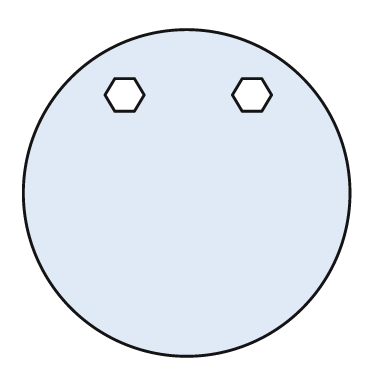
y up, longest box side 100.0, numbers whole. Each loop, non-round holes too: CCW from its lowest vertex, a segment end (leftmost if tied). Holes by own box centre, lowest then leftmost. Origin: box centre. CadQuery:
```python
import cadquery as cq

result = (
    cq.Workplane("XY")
    .moveTo(0.0, 0.0)
    .circle(50.0)
    .moveTo(-22.0, 25.0)
    .lineTo(-16.0, 25.0)
    .lineTo(-13.0, 30.0)
    .lineTo(-16.0, 35.0)
    .lineTo(-22.0, 35.0)
    .lineTo(-25.0, 30.0)
    .close()
    .moveTo(17.0, 25.0)
    .lineTo(23.0, 25.0)
    .lineTo(26.0, 30.0)
    .lineTo(23.0, 35.0)
    .lineTo(17.0, 35.0)
    .lineTo(14.0, 30.0)
    .close()
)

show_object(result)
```